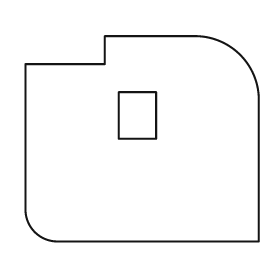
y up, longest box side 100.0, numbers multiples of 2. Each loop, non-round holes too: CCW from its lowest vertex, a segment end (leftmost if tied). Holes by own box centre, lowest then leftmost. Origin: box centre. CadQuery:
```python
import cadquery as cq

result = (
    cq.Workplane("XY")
    .moveTo(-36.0, -44.0)
    .lineTo(50.0, -44.0)
    .lineTo(50.0, 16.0)
    .threePointArc((42.0, 36.0), (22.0, 44.0))
    .lineTo(-16.0, 44.0)
    .lineTo(-16.0, 32.0)
    .lineTo(-50.0, 32.0)
    .lineTo(-50.0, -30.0)
    .threePointArc((-46.0, -40.0), (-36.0, -44.0))
    .close()
    .moveTo(-10.0, 0.0)
    .lineTo(6.0, 0.0)
    .lineTo(6.0, 20.0)
    .lineTo(-10.0, 20.0)
    .close()
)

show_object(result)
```